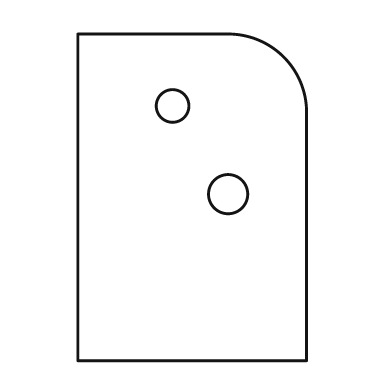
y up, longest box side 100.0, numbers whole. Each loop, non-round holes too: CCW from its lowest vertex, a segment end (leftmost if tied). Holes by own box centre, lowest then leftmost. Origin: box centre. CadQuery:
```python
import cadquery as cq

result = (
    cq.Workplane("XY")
    .moveTo(-35.0, -50.0)
    .lineTo(35.0, -50.0)
    .lineTo(35.0, 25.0)
    .threePointArc((28.0, 43.0), (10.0, 50.0))
    .lineTo(-35.0, 50.0)
    .close()
    .moveTo(11.0, 1.0)
    .circle(6.0)
    .moveTo(-6.0, 28.0)
    .circle(5.0)
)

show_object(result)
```